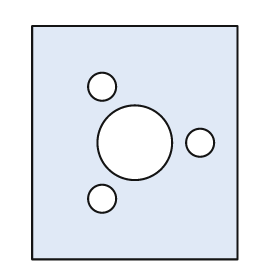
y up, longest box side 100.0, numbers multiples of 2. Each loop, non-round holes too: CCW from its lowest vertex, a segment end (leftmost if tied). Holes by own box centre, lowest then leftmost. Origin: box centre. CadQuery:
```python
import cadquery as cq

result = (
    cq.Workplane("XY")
    .moveTo(-44.0, -50.0)
    .lineTo(44.0, -50.0)
    .lineTo(44.0, 50.0)
    .lineTo(-44.0, 50.0)
    .close()
    .moveTo(-14.0, -24.0)
    .circle(6.0)
    .moveTo(0.0, 0.0)
    .circle(16.0)
    .moveTo(28.0, 0.0)
    .circle(6.0)
    .moveTo(-14.0, 24.0)
    .circle(6.0)
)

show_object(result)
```